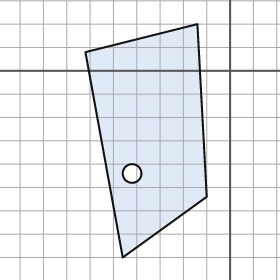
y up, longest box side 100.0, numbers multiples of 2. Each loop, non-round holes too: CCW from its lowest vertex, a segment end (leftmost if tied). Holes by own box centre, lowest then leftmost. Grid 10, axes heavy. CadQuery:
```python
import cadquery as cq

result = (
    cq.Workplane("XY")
    .moveTo(-46.0, -80.0)
    .lineTo(-10.0, -54.0)
    .lineTo(-14.0, 20.0)
    .lineTo(-62.0, 8.0)
    .close()
    .moveTo(-42.0, -44.0)
    .circle(4.0)
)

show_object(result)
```